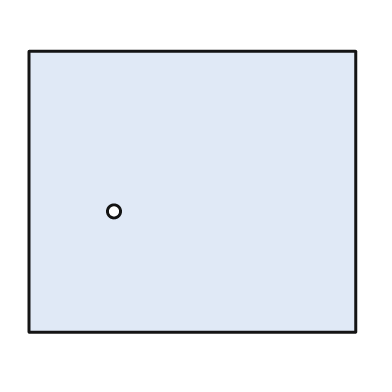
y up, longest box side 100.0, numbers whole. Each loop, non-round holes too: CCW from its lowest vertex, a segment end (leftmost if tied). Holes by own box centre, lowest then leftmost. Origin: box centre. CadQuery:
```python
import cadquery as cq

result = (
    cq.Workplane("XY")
    .moveTo(-50.0, -43.0)
    .lineTo(50.0, -43.0)
    .lineTo(50.0, 43.0)
    .lineTo(-50.0, 43.0)
    .close()
    .moveTo(-24.0, -6.0)
    .circle(2.0)
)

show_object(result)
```